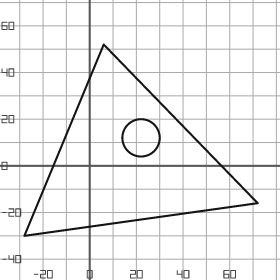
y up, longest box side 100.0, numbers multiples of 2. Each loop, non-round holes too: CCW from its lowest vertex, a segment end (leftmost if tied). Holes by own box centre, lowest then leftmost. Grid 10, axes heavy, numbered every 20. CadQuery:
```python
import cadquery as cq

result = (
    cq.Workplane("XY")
    .moveTo(-28.0, -30.0)
    .lineTo(72.0, -16.0)
    .lineTo(6.0, 52.0)
    .close()
    .moveTo(22.0, 12.0)
    .circle(8.0)
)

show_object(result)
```